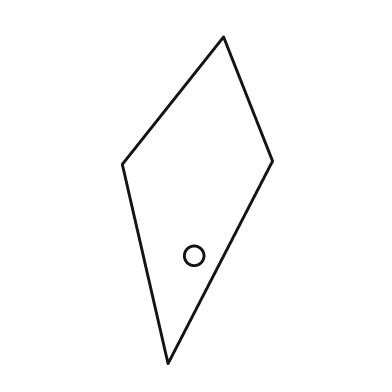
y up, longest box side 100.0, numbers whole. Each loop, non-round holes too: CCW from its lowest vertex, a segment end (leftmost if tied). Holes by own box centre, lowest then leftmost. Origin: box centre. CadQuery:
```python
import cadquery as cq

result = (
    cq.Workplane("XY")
    .moveTo(-9.0, -50.0)
    .lineTo(23.0, 12.0)
    .lineTo(8.0, 50.0)
    .lineTo(-23.0, 11.0)
    .close()
    .moveTo(-1.0, -17.0)
    .circle(3.0)
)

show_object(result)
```